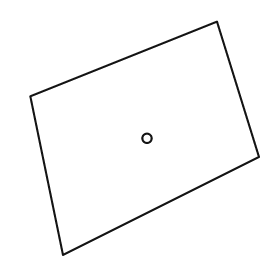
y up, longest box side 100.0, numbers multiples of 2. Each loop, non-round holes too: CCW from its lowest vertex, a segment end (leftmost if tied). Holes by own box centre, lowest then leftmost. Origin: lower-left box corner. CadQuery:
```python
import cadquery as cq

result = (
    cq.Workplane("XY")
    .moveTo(14.0, 0.0)
    .lineTo(98.0, 42.0)
    .lineTo(80.0, 100.0)
    .lineTo(0.0, 68.0)
    .close()
    .moveTo(50.0, 50.0)
    .circle(2.0)
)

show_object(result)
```